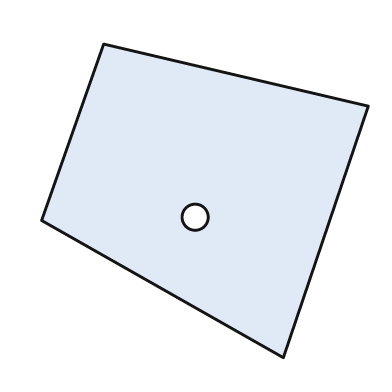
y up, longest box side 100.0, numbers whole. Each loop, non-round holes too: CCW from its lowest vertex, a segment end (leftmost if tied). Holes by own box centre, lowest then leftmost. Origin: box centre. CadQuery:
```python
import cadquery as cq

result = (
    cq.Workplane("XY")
    .moveTo(24.0, -48.0)
    .lineTo(50.0, 29.0)
    .lineTo(-31.0, 48.0)
    .lineTo(-50.0, -6.0)
    .close()
    .moveTo(-3.0, -5.0)
    .circle(4.0)
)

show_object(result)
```